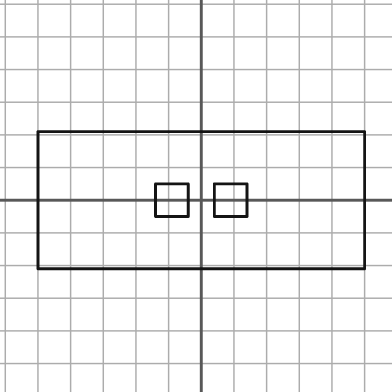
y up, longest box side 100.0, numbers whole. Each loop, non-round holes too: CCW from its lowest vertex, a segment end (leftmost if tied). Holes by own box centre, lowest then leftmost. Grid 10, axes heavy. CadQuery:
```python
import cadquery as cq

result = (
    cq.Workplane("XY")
    .moveTo(-50.0, -21.0)
    .lineTo(50.0, -21.0)
    .lineTo(50.0, 21.0)
    .lineTo(-50.0, 21.0)
    .close()
    .moveTo(-14.0, -5.0)
    .lineTo(-4.0, -5.0)
    .lineTo(-4.0, 5.0)
    .lineTo(-14.0, 5.0)
    .close()
    .moveTo(4.0, -5.0)
    .lineTo(14.0, -5.0)
    .lineTo(14.0, 5.0)
    .lineTo(4.0, 5.0)
    .close()
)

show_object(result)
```